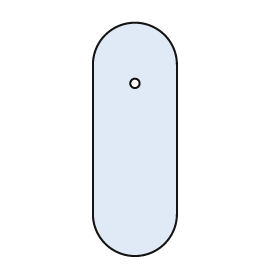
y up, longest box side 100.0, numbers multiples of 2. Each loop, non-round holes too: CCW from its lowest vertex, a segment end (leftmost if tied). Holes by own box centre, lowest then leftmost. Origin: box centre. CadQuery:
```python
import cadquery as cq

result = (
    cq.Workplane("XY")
    .moveTo(-18.0, -32.0)
    .threePointArc((0.0, -50.0), (18.0, -32.0))
    .lineTo(18.0, 32.0)
    .threePointArc((0.0, 50.0), (-18.0, 32.0))
    .close()
    .moveTo(0.0, 24.0)
    .circle(2.0)
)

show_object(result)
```